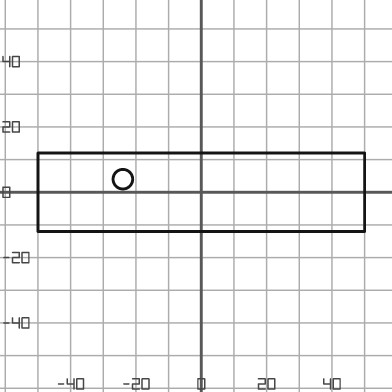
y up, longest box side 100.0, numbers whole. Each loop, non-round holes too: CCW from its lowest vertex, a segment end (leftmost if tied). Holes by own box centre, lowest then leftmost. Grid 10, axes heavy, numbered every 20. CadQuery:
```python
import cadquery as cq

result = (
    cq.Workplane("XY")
    .moveTo(-50.0, -12.0)
    .lineTo(50.0, -12.0)
    .lineTo(50.0, 12.0)
    .lineTo(-50.0, 12.0)
    .close()
    .moveTo(-24.0, 4.0)
    .circle(3.0)
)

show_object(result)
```